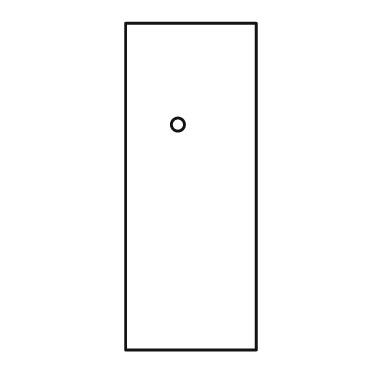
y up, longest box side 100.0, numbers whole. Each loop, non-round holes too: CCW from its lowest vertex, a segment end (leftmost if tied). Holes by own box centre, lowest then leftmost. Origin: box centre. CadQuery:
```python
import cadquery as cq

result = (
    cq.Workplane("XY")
    .moveTo(-20.0, -50.0)
    .lineTo(20.0, -50.0)
    .lineTo(20.0, 50.0)
    .lineTo(-20.0, 50.0)
    .close()
    .moveTo(-4.0, 19.0)
    .circle(2.0)
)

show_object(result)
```